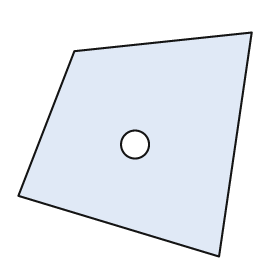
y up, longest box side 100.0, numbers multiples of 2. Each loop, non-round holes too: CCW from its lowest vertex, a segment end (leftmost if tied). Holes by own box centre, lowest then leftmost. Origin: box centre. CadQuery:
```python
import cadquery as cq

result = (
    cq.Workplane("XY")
    .moveTo(36.0, -48.0)
    .lineTo(50.0, 48.0)
    .lineTo(-26.0, 40.0)
    .lineTo(-50.0, -22.0)
    .close()
    .moveTo(0.0, 0.0)
    .circle(6.0)
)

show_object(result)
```